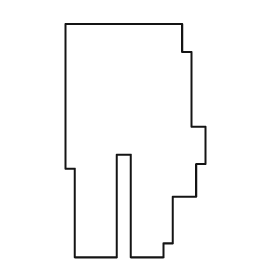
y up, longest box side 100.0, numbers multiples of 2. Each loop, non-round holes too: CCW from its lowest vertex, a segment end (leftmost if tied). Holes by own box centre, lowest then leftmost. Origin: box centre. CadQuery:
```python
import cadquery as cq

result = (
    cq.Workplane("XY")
    .moveTo(-26.0, -50.0)
    .lineTo(-8.0, -50.0)
    .lineTo(-8.0, -6.0)
    .lineTo(-2.0, -6.0)
    .lineTo(-2.0, -50.0)
    .lineTo(12.0, -50.0)
    .lineTo(12.0, -44.0)
    .lineTo(16.0, -44.0)
    .lineTo(16.0, -24.0)
    .lineTo(26.0, -24.0)
    .lineTo(26.0, -10.0)
    .lineTo(30.0, -10.0)
    .lineTo(30.0, 6.0)
    .lineTo(24.0, 6.0)
    .lineTo(24.0, 38.0)
    .lineTo(20.0, 38.0)
    .lineTo(20.0, 50.0)
    .lineTo(-30.0, 50.0)
    .lineTo(-30.0, -12.0)
    .lineTo(-26.0, -12.0)
    .close()
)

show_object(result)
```